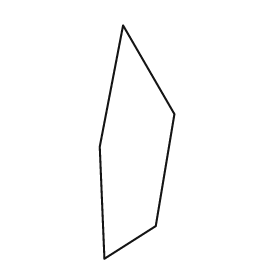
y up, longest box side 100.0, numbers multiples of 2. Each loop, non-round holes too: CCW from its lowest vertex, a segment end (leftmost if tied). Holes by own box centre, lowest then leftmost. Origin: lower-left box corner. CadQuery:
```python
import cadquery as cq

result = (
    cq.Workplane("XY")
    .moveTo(2.0, 0.0)
    .lineTo(24.0, 14.0)
    .lineTo(32.0, 62.0)
    .lineTo(10.0, 100.0)
    .lineTo(0.0, 48.0)
    .close()
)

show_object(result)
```